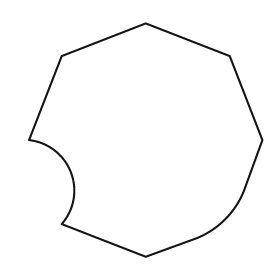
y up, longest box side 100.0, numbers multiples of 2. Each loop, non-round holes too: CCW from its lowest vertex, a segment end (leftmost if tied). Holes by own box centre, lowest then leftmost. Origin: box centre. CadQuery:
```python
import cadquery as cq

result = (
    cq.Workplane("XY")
    .moveTo(0.0, -50.0)
    .lineTo(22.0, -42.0)
    .threePointArc((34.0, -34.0), (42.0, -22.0))
    .lineTo(50.0, 0.0)
    .lineTo(36.0, 36.0)
    .lineTo(0.0, 50.0)
    .lineTo(-36.0, 36.0)
    .lineTo(-50.0, 0.0)
    .threePointArc((-32.0, -14.0), (-36.0, -36.0))
    .close()
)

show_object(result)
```